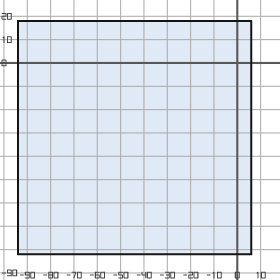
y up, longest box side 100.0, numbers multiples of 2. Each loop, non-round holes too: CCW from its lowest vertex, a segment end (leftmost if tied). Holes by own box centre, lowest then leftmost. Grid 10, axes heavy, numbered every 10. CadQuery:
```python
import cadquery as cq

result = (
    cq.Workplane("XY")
    .moveTo(-94.0, -82.0)
    .lineTo(6.0, -82.0)
    .lineTo(6.0, 18.0)
    .lineTo(-94.0, 18.0)
    .close()
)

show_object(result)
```